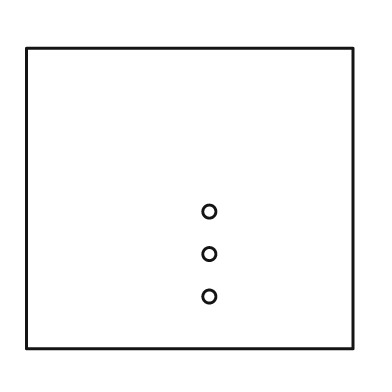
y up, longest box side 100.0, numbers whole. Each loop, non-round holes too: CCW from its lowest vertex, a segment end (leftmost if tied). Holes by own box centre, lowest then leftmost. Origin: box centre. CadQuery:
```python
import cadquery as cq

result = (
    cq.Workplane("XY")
    .moveTo(-50.0, -46.0)
    .lineTo(50.0, -46.0)
    .lineTo(50.0, 46.0)
    .lineTo(-50.0, 46.0)
    .close()
    .moveTo(6.0, -30.0)
    .circle(2.0)
    .moveTo(6.0, -17.0)
    .circle(2.0)
    .moveTo(6.0, -4.0)
    .circle(2.0)
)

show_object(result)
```